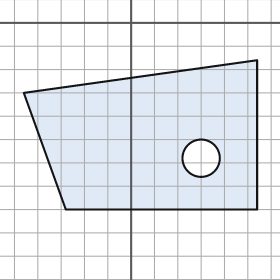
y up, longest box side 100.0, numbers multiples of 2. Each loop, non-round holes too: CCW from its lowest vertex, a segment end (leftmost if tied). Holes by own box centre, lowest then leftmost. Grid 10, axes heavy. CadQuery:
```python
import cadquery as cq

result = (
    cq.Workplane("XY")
    .moveTo(-28.0, -80.0)
    .lineTo(54.0, -80.0)
    .lineTo(54.0, -16.0)
    .lineTo(-46.0, -30.0)
    .close()
    .moveTo(30.0, -58.0)
    .circle(8.0)
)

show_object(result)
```